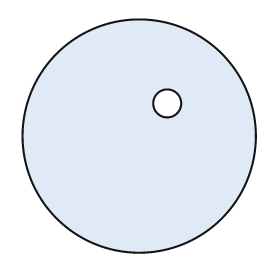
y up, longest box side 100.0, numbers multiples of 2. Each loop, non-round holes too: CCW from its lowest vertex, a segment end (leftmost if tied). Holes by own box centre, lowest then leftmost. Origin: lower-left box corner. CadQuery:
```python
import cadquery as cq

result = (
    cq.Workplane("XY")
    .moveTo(50.0, 50.0)
    .circle(50.0)
    .moveTo(62.0, 64.0)
    .circle(6.0)
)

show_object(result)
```